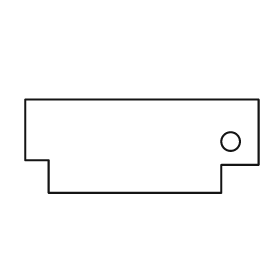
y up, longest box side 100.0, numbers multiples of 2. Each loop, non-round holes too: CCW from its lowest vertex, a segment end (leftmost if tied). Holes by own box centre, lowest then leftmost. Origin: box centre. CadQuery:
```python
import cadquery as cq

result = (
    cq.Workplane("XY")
    .moveTo(-40.0, -20.0)
    .lineTo(34.0, -20.0)
    .lineTo(34.0, -8.0)
    .lineTo(50.0, -8.0)
    .lineTo(50.0, 20.0)
    .lineTo(-50.0, 20.0)
    .lineTo(-50.0, -6.0)
    .lineTo(-40.0, -6.0)
    .close()
    .moveTo(38.0, 2.0)
    .circle(4.0)
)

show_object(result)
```